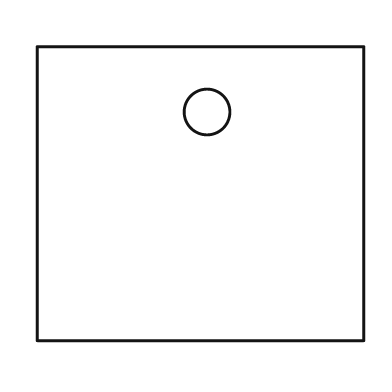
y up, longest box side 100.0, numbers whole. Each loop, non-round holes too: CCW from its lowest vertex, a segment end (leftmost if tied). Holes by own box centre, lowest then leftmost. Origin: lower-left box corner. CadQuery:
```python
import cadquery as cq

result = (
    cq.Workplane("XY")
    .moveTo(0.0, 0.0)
    .lineTo(100.0, 0.0)
    .lineTo(100.0, 90.0)
    .lineTo(0.0, 90.0)
    .close()
    .moveTo(52.0, 70.0)
    .circle(7.0)
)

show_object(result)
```